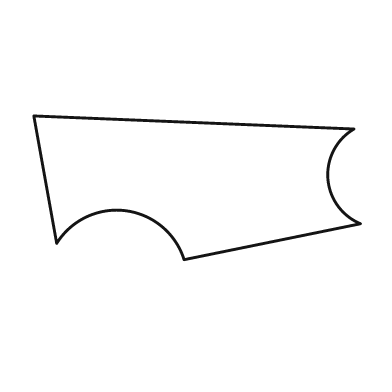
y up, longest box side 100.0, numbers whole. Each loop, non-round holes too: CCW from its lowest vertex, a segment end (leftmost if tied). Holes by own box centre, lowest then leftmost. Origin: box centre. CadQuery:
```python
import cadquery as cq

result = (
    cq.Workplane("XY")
    .moveTo(-4.0, -22.0)
    .lineTo(50.0, -11.0)
    .threePointArc((40.0, 3.0), (48.0, 18.0))
    .lineTo(-50.0, 22.0)
    .lineTo(-43.0, -17.0)
    .threePointArc((-22.0, -7.0), (-4.0, -22.0))
    .close()
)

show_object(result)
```